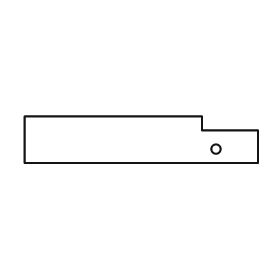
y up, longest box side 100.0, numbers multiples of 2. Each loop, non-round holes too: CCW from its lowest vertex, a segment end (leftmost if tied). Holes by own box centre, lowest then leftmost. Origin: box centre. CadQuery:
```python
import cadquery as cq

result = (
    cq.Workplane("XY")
    .moveTo(-50.0, -10.0)
    .lineTo(50.0, -10.0)
    .lineTo(50.0, 4.0)
    .lineTo(26.0, 4.0)
    .lineTo(26.0, 10.0)
    .lineTo(-50.0, 10.0)
    .close()
    .moveTo(32.0, -4.0)
    .circle(2.0)
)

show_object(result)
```